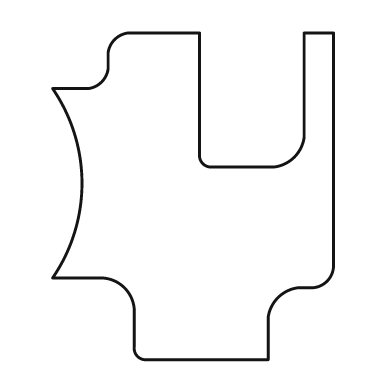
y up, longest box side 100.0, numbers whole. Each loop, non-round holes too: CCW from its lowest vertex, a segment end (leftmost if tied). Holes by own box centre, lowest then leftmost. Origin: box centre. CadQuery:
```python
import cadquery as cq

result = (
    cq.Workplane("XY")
    .moveTo(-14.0, -50.0)
    .lineTo(23.0, -50.0)
    .lineTo(23.0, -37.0)
    .threePointArc((26.0, -31.0), (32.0, -28.0))
    .lineTo(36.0, -28.0)
    .threePointArc((41.0, -26.0), (43.0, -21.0))
    .lineTo(43.0, 50.0)
    .lineTo(34.0, 50.0)
    .lineTo(34.0, 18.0)
    .threePointArc((31.0, 12.0), (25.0, 9.0))
    .lineTo(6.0, 9.0)
    .threePointArc((3.0, 10.0), (2.0, 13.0))
    .lineTo(2.0, 50.0)
    .lineTo(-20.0, 50.0)
    .threePointArc((-24.0, 48.0), (-26.0, 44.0))
    .lineTo(-26.0, 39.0)
    .threePointArc((-28.0, 35.0), (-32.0, 33.0))
    .lineTo(-43.0, 33.0)
    .threePointArc((-34.0, 4.0), (-43.0, -25.0))
    .lineTo(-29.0, -25.0)
    .threePointArc((-21.0, -28.0), (-18.0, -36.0))
    .lineTo(-18.0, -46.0)
    .threePointArc((-17.0, -49.0), (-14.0, -50.0))
    .close()
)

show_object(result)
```